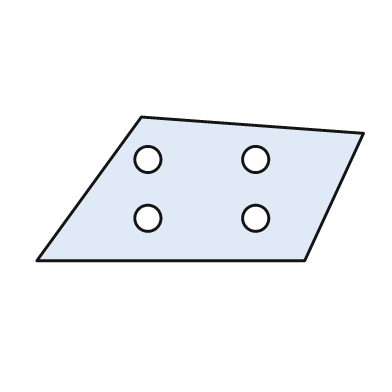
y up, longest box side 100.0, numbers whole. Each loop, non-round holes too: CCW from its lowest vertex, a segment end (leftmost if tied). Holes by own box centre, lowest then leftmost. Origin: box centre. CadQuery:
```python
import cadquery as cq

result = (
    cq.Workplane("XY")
    .moveTo(-50.0, -22.0)
    .lineTo(32.0, -22.0)
    .lineTo(50.0, 17.0)
    .lineTo(-18.0, 22.0)
    .close()
    .moveTo(-16.0, -9.0)
    .circle(4.0)
    .moveTo(17.0, -9.0)
    .circle(4.0)
    .moveTo(-16.0, 9.0)
    .circle(4.0)
    .moveTo(17.0, 9.0)
    .circle(4.0)
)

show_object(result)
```